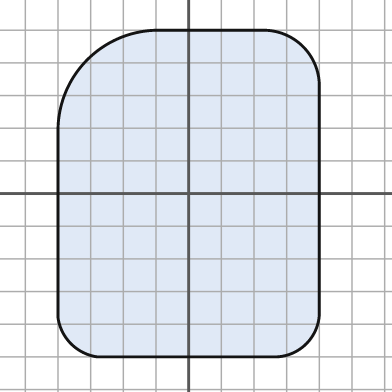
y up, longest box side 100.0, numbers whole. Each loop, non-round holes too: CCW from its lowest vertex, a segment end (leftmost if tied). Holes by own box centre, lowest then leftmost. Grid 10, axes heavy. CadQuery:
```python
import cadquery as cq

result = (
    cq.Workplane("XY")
    .moveTo(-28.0, -50.0)
    .lineTo(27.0, -50.0)
    .threePointArc((36.0, -46.0), (40.0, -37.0))
    .lineTo(40.0, 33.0)
    .threePointArc((35.0, 45.0), (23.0, 50.0))
    .lineTo(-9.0, 50.0)
    .threePointArc((-31.0, 41.0), (-40.0, 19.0))
    .lineTo(-40.0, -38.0)
    .threePointArc((-36.0, -46.0), (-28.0, -50.0))
    .close()
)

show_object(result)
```